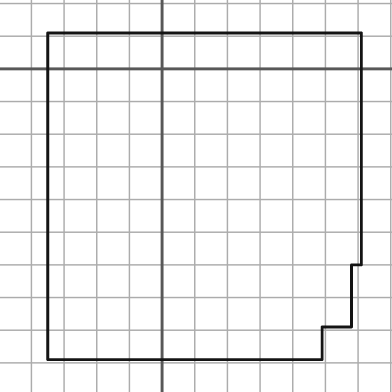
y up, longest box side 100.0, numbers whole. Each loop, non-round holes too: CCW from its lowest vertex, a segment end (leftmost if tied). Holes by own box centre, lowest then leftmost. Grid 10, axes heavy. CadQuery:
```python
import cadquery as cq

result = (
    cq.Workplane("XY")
    .moveTo(-35.0, -89.0)
    .lineTo(49.0, -89.0)
    .lineTo(49.0, -79.0)
    .lineTo(58.0, -79.0)
    .lineTo(58.0, -60.0)
    .lineTo(61.0, -60.0)
    .lineTo(61.0, 11.0)
    .lineTo(-35.0, 11.0)
    .close()
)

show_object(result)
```